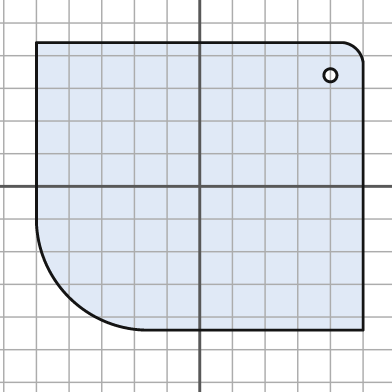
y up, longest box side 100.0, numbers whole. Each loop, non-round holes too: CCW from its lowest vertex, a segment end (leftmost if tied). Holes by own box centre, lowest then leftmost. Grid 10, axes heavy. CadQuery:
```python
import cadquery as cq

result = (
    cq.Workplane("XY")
    .moveTo(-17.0, -44.0)
    .lineTo(50.0, -44.0)
    .lineTo(50.0, 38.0)
    .threePointArc((48.0, 42.0), (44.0, 44.0))
    .lineTo(-50.0, 44.0)
    .lineTo(-50.0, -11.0)
    .threePointArc((-40.0, -34.0), (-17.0, -44.0))
    .close()
    .moveTo(40.0, 34.0)
    .circle(2.0)
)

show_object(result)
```